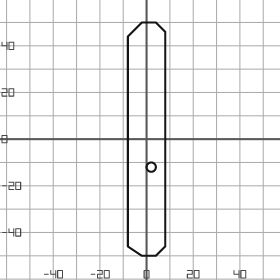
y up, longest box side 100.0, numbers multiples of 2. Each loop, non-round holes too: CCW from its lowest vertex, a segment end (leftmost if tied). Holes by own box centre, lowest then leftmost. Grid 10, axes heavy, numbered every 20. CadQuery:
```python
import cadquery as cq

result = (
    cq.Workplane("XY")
    .moveTo(-2.0, -50.0)
    .lineTo(4.0, -50.0)
    .lineTo(8.0, -46.0)
    .lineTo(8.0, 46.0)
    .lineTo(4.0, 50.0)
    .lineTo(-2.0, 50.0)
    .lineTo(-8.0, 44.0)
    .lineTo(-8.0, -46.0)
    .close()
    .moveTo(2.0, -12.0)
    .circle(2.0)
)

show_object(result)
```